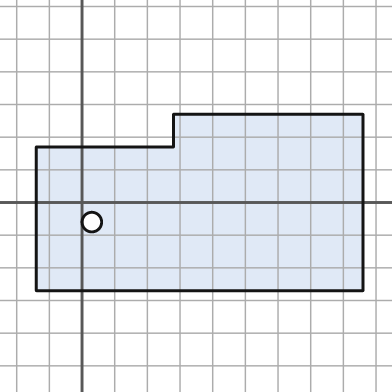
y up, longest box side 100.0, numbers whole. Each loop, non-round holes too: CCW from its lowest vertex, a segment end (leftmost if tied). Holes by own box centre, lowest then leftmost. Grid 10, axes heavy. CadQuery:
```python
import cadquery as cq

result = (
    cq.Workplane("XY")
    .moveTo(-14.0, -27.0)
    .lineTo(86.0, -27.0)
    .lineTo(86.0, 27.0)
    .lineTo(28.0, 27.0)
    .lineTo(28.0, 17.0)
    .lineTo(-14.0, 17.0)
    .close()
    .moveTo(3.0, -6.0)
    .circle(3.0)
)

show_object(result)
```